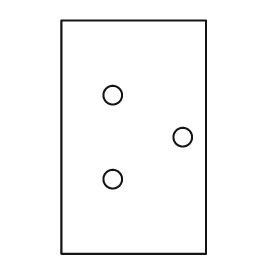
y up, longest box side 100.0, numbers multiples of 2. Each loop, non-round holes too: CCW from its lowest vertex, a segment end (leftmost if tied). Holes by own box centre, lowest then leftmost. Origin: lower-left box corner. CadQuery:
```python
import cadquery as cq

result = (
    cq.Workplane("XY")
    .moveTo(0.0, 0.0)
    .lineTo(62.0, 0.0)
    .lineTo(62.0, 100.0)
    .lineTo(0.0, 100.0)
    .close()
    .moveTo(22.0, 32.0)
    .circle(4.0)
    .moveTo(52.0, 50.0)
    .circle(4.0)
    .moveTo(22.0, 68.0)
    .circle(4.0)
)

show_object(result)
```